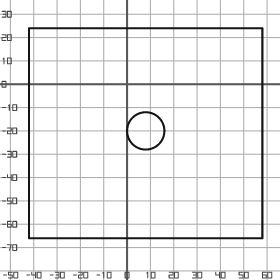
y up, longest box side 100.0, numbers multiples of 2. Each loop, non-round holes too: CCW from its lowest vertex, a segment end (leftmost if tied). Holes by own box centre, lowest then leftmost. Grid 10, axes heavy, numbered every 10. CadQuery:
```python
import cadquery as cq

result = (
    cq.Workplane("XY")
    .moveTo(-42.0, -66.0)
    .lineTo(58.0, -66.0)
    .lineTo(58.0, 24.0)
    .lineTo(-42.0, 24.0)
    .close()
    .moveTo(8.0, -20.0)
    .circle(8.0)
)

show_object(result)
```